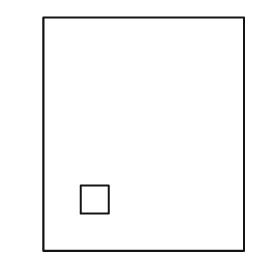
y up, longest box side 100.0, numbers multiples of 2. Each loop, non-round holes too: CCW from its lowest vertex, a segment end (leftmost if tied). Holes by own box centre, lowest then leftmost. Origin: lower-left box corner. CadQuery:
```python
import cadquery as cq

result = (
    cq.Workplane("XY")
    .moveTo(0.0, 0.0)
    .lineTo(86.0, 0.0)
    .lineTo(86.0, 100.0)
    .lineTo(0.0, 100.0)
    .close()
    .moveTo(16.0, 16.0)
    .lineTo(28.0, 16.0)
    .lineTo(28.0, 28.0)
    .lineTo(16.0, 28.0)
    .close()
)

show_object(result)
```